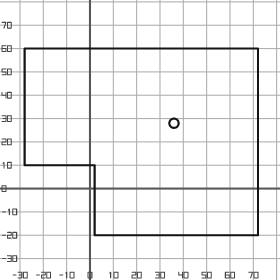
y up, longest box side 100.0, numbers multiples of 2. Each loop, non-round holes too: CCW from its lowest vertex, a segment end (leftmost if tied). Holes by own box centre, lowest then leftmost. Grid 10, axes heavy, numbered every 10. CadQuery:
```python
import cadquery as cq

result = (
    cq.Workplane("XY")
    .moveTo(2.0, -20.0)
    .lineTo(72.0, -20.0)
    .lineTo(72.0, 60.0)
    .lineTo(-28.0, 60.0)
    .lineTo(-28.0, 10.0)
    .lineTo(2.0, 10.0)
    .close()
    .moveTo(36.0, 28.0)
    .circle(2.0)
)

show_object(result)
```